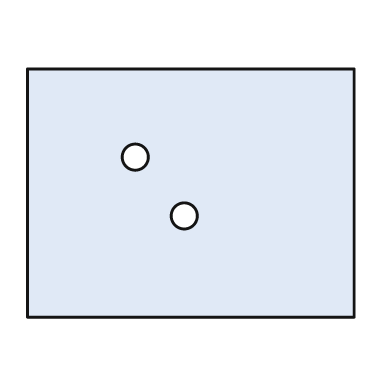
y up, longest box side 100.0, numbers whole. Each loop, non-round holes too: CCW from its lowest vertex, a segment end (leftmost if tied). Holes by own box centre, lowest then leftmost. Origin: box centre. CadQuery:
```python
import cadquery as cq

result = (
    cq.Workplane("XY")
    .moveTo(-50.0, -38.0)
    .lineTo(50.0, -38.0)
    .lineTo(50.0, 38.0)
    .lineTo(-50.0, 38.0)
    .close()
    .moveTo(-2.0, -7.0)
    .circle(4.0)
    .moveTo(-17.0, 11.0)
    .circle(4.0)
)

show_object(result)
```